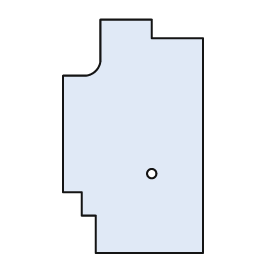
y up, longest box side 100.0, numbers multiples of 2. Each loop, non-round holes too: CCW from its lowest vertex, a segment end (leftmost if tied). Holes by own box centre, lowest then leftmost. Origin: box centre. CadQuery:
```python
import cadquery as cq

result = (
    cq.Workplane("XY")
    .moveTo(-16.0, -50.0)
    .lineTo(30.0, -50.0)
    .lineTo(30.0, 42.0)
    .lineTo(8.0, 42.0)
    .lineTo(8.0, 50.0)
    .lineTo(-14.0, 50.0)
    .lineTo(-14.0, 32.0)
    .threePointArc((-16.0, 28.0), (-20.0, 26.0))
    .lineTo(-30.0, 26.0)
    .lineTo(-30.0, -24.0)
    .lineTo(-22.0, -24.0)
    .lineTo(-22.0, -34.0)
    .lineTo(-16.0, -34.0)
    .close()
    .moveTo(8.0, -16.0)
    .circle(2.0)
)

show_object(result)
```